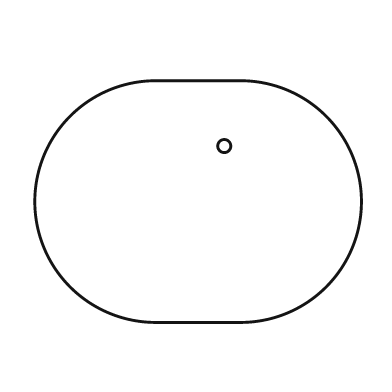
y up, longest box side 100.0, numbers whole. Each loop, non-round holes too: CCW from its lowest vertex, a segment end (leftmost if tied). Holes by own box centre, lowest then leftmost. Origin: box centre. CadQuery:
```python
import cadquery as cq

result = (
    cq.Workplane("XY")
    .moveTo(-13.0, -37.0)
    .lineTo(13.0, -37.0)
    .threePointArc((50.0, 0.0), (13.0, 37.0))
    .lineTo(-13.0, 37.0)
    .threePointArc((-50.0, 0.0), (-13.0, -37.0))
    .close()
    .moveTo(8.0, 17.0)
    .circle(2.0)
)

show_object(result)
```